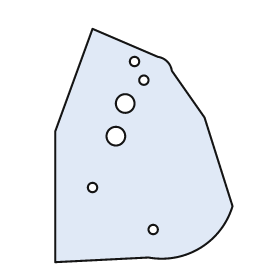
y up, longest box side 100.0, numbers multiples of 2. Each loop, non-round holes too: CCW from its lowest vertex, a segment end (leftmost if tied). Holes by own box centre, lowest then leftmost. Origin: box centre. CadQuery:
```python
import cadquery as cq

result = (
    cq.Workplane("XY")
    .moveTo(-38.0, -50.0)
    .lineTo(2.0, -48.0)
    .threePointArc((24.0, -44.0), (38.0, -26.0))
    .lineTo(26.0, 12.0)
    .lineTo(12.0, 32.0)
    .threePointArc((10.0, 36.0), (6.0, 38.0))
    .lineTo(-22.0, 50.0)
    .lineTo(-38.0, 6.0)
    .close()
    .moveTo(4.0, -36.0)
    .circle(2.0)
    .moveTo(-22.0, -18.0)
    .circle(2.0)
    .moveTo(-12.0, 4.0)
    .circle(4.0)
    .moveTo(-8.0, 18.0)
    .circle(4.0)
    .moveTo(0.0, 28.0)
    .circle(2.0)
    .moveTo(-4.0, 36.0)
    .circle(2.0)
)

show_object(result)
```